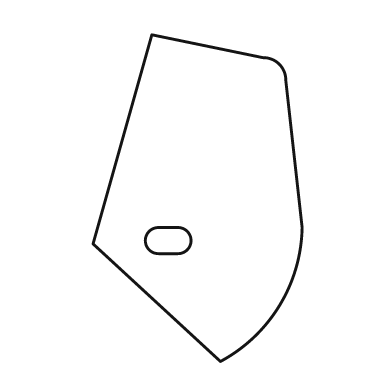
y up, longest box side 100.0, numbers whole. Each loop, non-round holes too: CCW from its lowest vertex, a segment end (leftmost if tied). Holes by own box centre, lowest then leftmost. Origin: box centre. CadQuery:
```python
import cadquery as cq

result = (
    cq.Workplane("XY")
    .moveTo(7.0, -50.0)
    .threePointArc((25.0, -33.0), (32.0, -9.0))
    .lineTo(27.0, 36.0)
    .threePointArc((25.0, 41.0), (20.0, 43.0))
    .lineTo(-14.0, 50.0)
    .lineTo(-32.0, -14.0)
    .close()
    .moveTo(-12.0, -17.0)
    .lineTo(-6.0, -17.0)
    .threePointArc((-2.0, -13.0), (-6.0, -9.0))
    .lineTo(-12.0, -9.0)
    .threePointArc((-16.0, -13.0), (-12.0, -17.0))
    .close()
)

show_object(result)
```